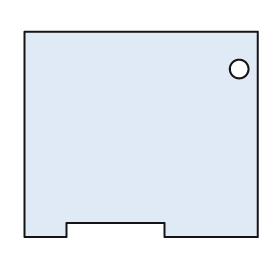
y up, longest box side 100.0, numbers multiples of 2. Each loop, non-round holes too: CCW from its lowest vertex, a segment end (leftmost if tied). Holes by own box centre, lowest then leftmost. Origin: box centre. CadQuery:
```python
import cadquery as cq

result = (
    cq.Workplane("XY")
    .moveTo(-50.0, -44.0)
    .lineTo(-32.0, -44.0)
    .lineTo(-32.0, -38.0)
    .lineTo(10.0, -38.0)
    .lineTo(10.0, -44.0)
    .lineTo(50.0, -44.0)
    .lineTo(50.0, 44.0)
    .lineTo(-50.0, 44.0)
    .close()
    .moveTo(42.0, 28.0)
    .circle(4.0)
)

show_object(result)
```